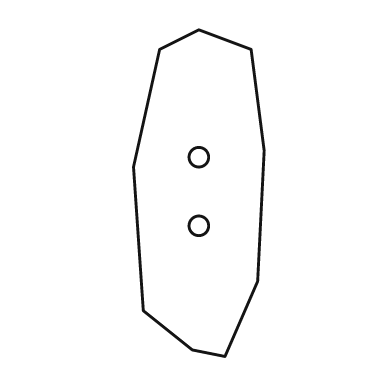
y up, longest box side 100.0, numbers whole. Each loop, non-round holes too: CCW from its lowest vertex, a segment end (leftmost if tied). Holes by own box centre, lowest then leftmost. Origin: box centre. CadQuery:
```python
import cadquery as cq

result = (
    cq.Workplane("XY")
    .moveTo(8.0, -50.0)
    .lineTo(18.0, -27.0)
    .lineTo(20.0, 13.0)
    .lineTo(16.0, 44.0)
    .lineTo(0.0, 50.0)
    .lineTo(-12.0, 44.0)
    .lineTo(-20.0, 8.0)
    .lineTo(-17.0, -36.0)
    .lineTo(-2.0, -48.0)
    .close()
    .moveTo(0.0, -10.0)
    .circle(3.0)
    .moveTo(0.0, 11.0)
    .circle(3.0)
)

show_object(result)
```